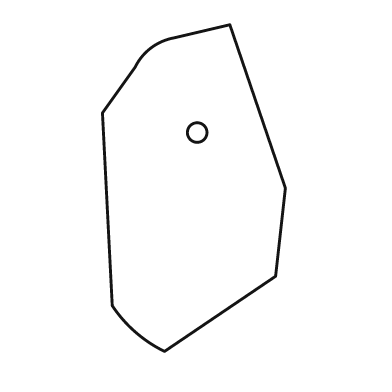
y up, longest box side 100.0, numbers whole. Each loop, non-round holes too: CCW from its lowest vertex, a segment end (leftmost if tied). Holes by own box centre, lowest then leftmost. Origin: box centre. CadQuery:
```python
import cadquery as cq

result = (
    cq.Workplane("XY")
    .moveTo(-9.0, -50.0)
    .lineTo(25.0, -27.0)
    .lineTo(28.0, 0.0)
    .lineTo(11.0, 50.0)
    .lineTo(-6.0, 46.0)
    .threePointArc((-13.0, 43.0), (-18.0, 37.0))
    .lineTo(-28.0, 23.0)
    .lineTo(-25.0, -36.0)
    .threePointArc((-18.0, -44.0), (-9.0, -50.0))
    .close()
    .moveTo(1.0, 17.0)
    .circle(3.0)
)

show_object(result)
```